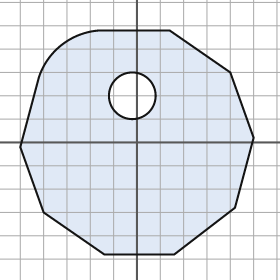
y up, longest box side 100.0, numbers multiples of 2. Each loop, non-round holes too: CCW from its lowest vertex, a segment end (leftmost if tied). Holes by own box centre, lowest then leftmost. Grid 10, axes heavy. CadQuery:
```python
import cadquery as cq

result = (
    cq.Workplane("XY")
    .moveTo(-14.0, -48.0)
    .lineTo(16.0, -48.0)
    .lineTo(42.0, -28.0)
    .lineTo(50.0, 2.0)
    .lineTo(40.0, 30.0)
    .lineTo(14.0, 48.0)
    .lineTo(-16.0, 48.0)
    .threePointArc((-32.0, 42.0), (-42.0, 28.0))
    .lineTo(-50.0, -2.0)
    .lineTo(-40.0, -30.0)
    .close()
    .moveTo(-2.0, 20.0)
    .circle(10.0)
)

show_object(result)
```